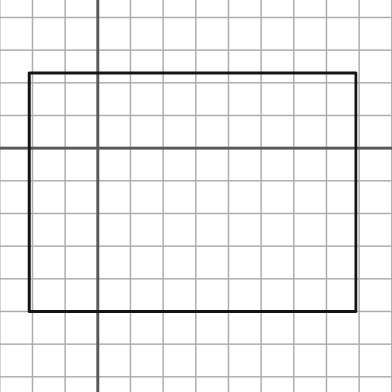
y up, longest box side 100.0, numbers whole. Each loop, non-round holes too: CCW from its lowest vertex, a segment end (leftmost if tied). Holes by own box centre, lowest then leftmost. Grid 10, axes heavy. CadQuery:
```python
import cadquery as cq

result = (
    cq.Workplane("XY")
    .moveTo(-21.0, -50.0)
    .lineTo(79.0, -50.0)
    .lineTo(79.0, 23.0)
    .lineTo(-21.0, 23.0)
    .close()
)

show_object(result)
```